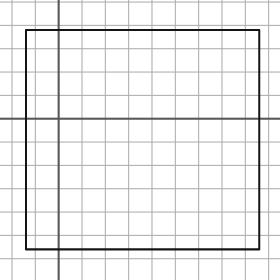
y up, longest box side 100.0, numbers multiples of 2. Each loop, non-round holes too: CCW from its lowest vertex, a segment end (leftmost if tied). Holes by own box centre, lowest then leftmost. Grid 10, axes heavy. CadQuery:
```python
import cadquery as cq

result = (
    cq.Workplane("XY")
    .moveTo(-14.0, -56.0)
    .lineTo(86.0, -56.0)
    .lineTo(86.0, 38.0)
    .lineTo(-14.0, 38.0)
    .close()
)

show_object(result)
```